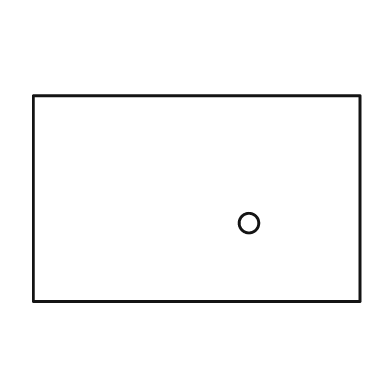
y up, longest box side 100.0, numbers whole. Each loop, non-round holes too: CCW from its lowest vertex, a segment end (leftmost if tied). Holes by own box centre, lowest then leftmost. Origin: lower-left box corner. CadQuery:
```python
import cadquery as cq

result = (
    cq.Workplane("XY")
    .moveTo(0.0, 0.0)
    .lineTo(100.0, 0.0)
    .lineTo(100.0, 63.0)
    .lineTo(0.0, 63.0)
    .close()
    .moveTo(66.0, 24.0)
    .circle(3.0)
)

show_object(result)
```